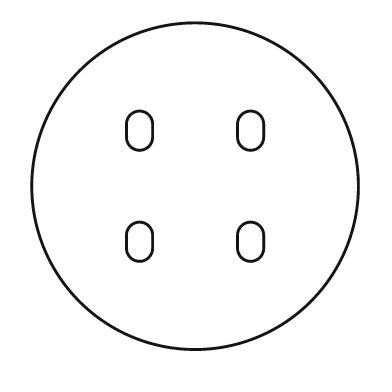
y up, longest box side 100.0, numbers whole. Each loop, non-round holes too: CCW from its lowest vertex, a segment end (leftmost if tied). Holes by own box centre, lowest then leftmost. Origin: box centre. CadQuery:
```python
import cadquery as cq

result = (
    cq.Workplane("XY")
    .moveTo(0.0, 0.0)
    .circle(50.0)
    .moveTo(-21.0, -19.0)
    .threePointArc((-17.0, -23.0), (-13.0, -19.0))
    .lineTo(-13.0, -15.0)
    .threePointArc((-17.0, -11.0), (-21.0, -15.0))
    .close()
    .moveTo(13.0, -19.0)
    .threePointArc((17.0, -23.0), (21.0, -19.0))
    .lineTo(21.0, -15.0)
    .threePointArc((17.0, -11.0), (13.0, -15.0))
    .close()
    .moveTo(-21.0, 15.0)
    .threePointArc((-17.0, 11.0), (-13.0, 15.0))
    .lineTo(-13.0, 19.0)
    .threePointArc((-17.0, 23.0), (-21.0, 19.0))
    .close()
    .moveTo(13.0, 15.0)
    .threePointArc((17.0, 11.0), (21.0, 15.0))
    .lineTo(21.0, 19.0)
    .threePointArc((17.0, 23.0), (13.0, 19.0))
    .close()
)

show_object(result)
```